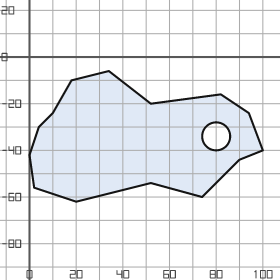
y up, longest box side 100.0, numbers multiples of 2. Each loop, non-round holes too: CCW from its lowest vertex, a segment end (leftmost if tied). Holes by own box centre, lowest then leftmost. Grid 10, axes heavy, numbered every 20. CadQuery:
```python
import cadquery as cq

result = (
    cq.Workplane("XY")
    .moveTo(20.0, -62.0)
    .lineTo(52.0, -54.0)
    .lineTo(74.0, -60.0)
    .lineTo(90.0, -44.0)
    .lineTo(100.0, -40.0)
    .lineTo(94.0, -24.0)
    .lineTo(82.0, -16.0)
    .lineTo(52.0, -20.0)
    .lineTo(34.0, -6.0)
    .lineTo(18.0, -10.0)
    .lineTo(10.0, -24.0)
    .lineTo(4.0, -30.0)
    .lineTo(0.0, -42.0)
    .lineTo(2.0, -56.0)
    .close()
    .moveTo(80.0, -34.0)
    .circle(6.0)
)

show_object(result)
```